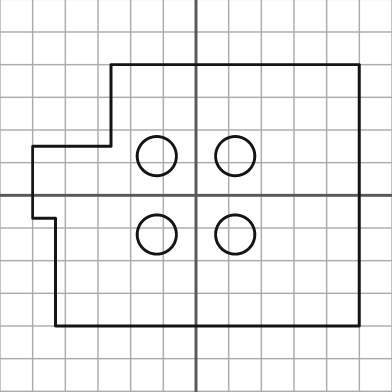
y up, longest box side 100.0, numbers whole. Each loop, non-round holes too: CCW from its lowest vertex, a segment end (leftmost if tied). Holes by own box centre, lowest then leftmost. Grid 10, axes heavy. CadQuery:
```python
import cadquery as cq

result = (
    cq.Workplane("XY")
    .moveTo(-43.0, -40.0)
    .lineTo(50.0, -40.0)
    .lineTo(50.0, 40.0)
    .lineTo(-26.0, 40.0)
    .lineTo(-26.0, 15.0)
    .lineTo(-50.0, 15.0)
    .lineTo(-50.0, -7.0)
    .lineTo(-43.0, -7.0)
    .close()
    .moveTo(-12.0, -12.0)
    .circle(6.0)
    .moveTo(12.0, -12.0)
    .circle(6.0)
    .moveTo(-12.0, 12.0)
    .circle(6.0)
    .moveTo(12.0, 12.0)
    .circle(6.0)
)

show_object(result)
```